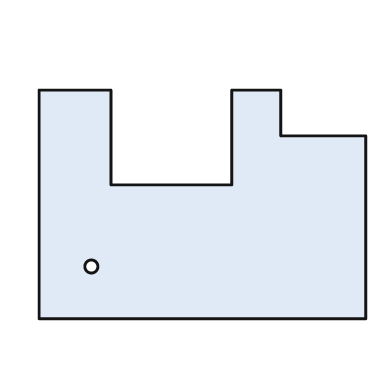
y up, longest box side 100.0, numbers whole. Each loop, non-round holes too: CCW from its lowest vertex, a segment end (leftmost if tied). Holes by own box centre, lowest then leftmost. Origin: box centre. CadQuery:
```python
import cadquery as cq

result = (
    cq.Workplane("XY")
    .moveTo(-50.0, -35.0)
    .lineTo(50.0, -35.0)
    .lineTo(50.0, 21.0)
    .lineTo(24.0, 21.0)
    .lineTo(24.0, 35.0)
    .lineTo(9.0, 35.0)
    .lineTo(9.0, 6.0)
    .lineTo(-28.0, 6.0)
    .lineTo(-28.0, 35.0)
    .lineTo(-50.0, 35.0)
    .close()
    .moveTo(-34.0, -19.0)
    .circle(2.0)
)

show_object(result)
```